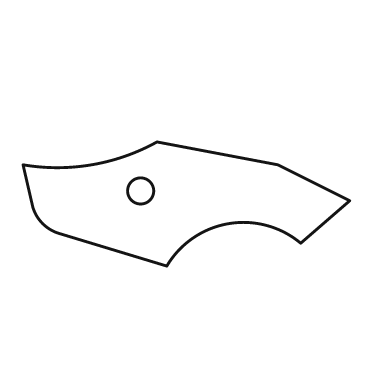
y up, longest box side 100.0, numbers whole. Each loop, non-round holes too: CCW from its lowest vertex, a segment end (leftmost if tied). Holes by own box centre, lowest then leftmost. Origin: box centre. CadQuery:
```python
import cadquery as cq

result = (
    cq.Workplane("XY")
    .moveTo(-6.0, -19.0)
    .threePointArc((13.0, -6.0), (35.0, -12.0))
    .lineTo(50.0, 1.0)
    .lineTo(28.0, 12.0)
    .lineTo(-9.0, 19.0)
    .threePointArc((-29.0, 12.0), (-50.0, 12.0))
    .lineTo(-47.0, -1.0)
    .threePointArc((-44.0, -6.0), (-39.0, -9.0))
    .close()
    .moveTo(-14.0, 4.0)
    .circle(4.0)
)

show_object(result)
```